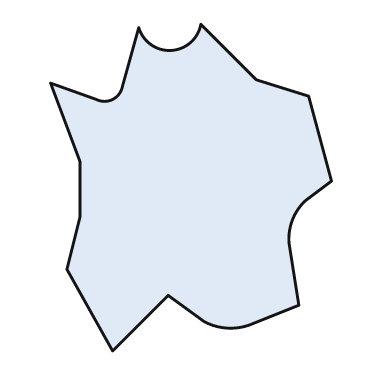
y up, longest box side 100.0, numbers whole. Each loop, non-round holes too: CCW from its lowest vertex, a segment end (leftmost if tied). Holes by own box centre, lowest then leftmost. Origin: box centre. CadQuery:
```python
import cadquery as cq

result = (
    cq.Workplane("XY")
    .moveTo(-24.0, -50.0)
    .lineTo(-7.0, -33.0)
    .lineTo(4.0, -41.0)
    .threePointArc((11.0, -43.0), (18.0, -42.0))
    .lineTo(33.0, -36.0)
    .lineTo(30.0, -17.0)
    .threePointArc((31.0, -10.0), (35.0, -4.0))
    .lineTo(43.0, 2.0)
    .lineTo(36.0, 28.0)
    .lineTo(20.0, 33.0)
    .lineTo(3.0, 50.0)
    .threePointArc((-6.0, 42.0), (-16.0, 49.0))
    .lineTo(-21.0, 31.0)
    .threePointArc((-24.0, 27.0), (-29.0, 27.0))
    .lineTo(-43.0, 32.0)
    .lineTo(-34.0, 8.0)
    .lineTo(-34.0, -9.0)
    .lineTo(-38.0, -25.0)
    .close()
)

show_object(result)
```